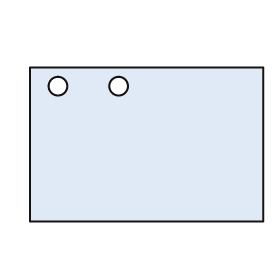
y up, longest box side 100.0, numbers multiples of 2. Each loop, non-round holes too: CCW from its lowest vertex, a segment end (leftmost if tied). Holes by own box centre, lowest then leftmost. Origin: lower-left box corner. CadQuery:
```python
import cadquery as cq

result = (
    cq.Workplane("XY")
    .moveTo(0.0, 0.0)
    .lineTo(100.0, 0.0)
    .lineTo(100.0, 66.0)
    .lineTo(0.0, 66.0)
    .close()
    .moveTo(12.0, 58.0)
    .circle(4.0)
    .moveTo(38.0, 58.0)
    .circle(4.0)
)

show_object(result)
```